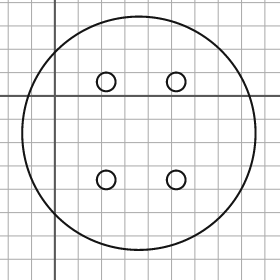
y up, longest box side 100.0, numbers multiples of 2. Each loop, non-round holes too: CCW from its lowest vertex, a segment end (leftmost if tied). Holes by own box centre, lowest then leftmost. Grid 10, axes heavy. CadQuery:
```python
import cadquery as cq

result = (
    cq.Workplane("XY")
    .moveTo(36.0, -16.0)
    .circle(50.0)
    .moveTo(22.0, -36.0)
    .circle(4.0)
    .moveTo(52.0, -36.0)
    .circle(4.0)
    .moveTo(22.0, 6.0)
    .circle(4.0)
    .moveTo(52.0, 6.0)
    .circle(4.0)
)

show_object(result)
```